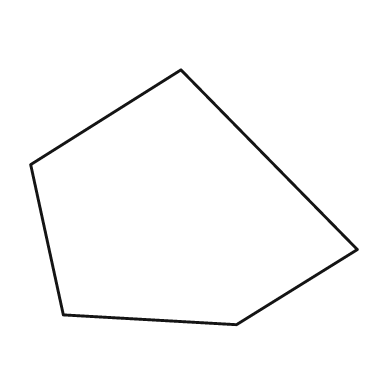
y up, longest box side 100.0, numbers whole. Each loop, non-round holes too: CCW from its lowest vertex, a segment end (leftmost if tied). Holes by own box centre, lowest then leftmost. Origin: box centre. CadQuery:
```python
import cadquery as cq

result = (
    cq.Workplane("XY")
    .moveTo(13.0, -39.0)
    .lineTo(50.0, -16.0)
    .lineTo(-4.0, 39.0)
    .lineTo(-50.0, 10.0)
    .lineTo(-40.0, -36.0)
    .close()
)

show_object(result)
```